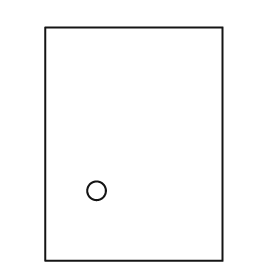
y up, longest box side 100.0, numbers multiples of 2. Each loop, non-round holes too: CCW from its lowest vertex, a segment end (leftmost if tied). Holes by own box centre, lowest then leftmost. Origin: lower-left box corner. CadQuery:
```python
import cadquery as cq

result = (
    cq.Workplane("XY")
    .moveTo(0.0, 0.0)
    .lineTo(76.0, 0.0)
    .lineTo(76.0, 100.0)
    .lineTo(0.0, 100.0)
    .close()
    .moveTo(22.0, 30.0)
    .circle(4.0)
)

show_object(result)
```